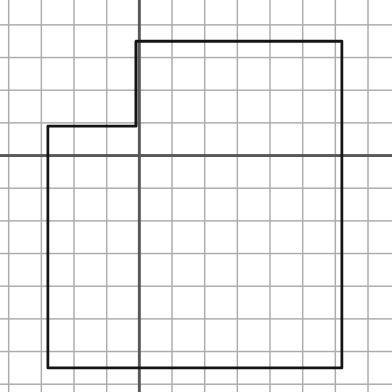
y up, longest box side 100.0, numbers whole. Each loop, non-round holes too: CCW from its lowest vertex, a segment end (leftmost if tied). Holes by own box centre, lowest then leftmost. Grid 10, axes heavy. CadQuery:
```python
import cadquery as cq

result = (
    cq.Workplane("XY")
    .moveTo(-28.0, -65.0)
    .lineTo(62.0, -65.0)
    .lineTo(62.0, 35.0)
    .lineTo(-1.0, 35.0)
    .lineTo(-1.0, 9.0)
    .lineTo(-28.0, 9.0)
    .close()
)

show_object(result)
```